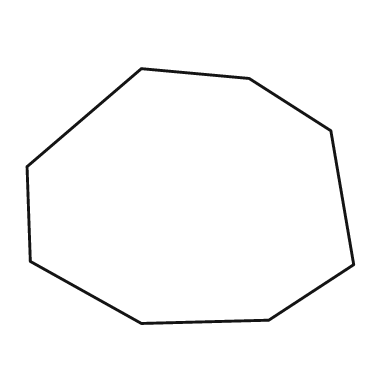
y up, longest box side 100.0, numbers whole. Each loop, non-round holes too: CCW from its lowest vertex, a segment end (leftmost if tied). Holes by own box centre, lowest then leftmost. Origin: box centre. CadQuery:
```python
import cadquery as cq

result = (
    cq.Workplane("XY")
    .moveTo(-15.0, -39.0)
    .lineTo(24.0, -38.0)
    .lineTo(50.0, -21.0)
    .lineTo(43.0, 20.0)
    .lineTo(18.0, 36.0)
    .lineTo(-15.0, 39.0)
    .lineTo(-50.0, 9.0)
    .lineTo(-49.0, -20.0)
    .close()
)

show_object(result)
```